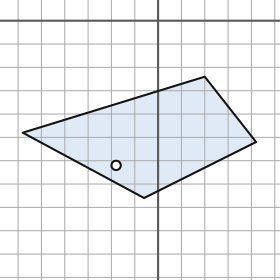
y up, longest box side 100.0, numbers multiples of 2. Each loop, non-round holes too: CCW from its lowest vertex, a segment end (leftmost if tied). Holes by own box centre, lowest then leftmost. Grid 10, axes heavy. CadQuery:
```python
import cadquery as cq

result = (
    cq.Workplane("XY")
    .moveTo(-6.0, -76.0)
    .lineTo(42.0, -52.0)
    .lineTo(20.0, -24.0)
    .lineTo(-58.0, -48.0)
    .close()
    .moveTo(-18.0, -62.0)
    .circle(2.0)
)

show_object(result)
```